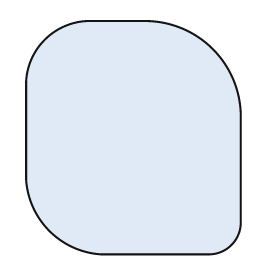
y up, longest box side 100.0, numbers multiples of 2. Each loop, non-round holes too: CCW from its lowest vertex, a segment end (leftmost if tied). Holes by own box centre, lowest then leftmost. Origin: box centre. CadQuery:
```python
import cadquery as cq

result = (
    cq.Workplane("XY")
    .moveTo(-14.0, -50.0)
    .lineTo(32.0, -50.0)
    .threePointArc((42.0, -46.0), (46.0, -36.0))
    .lineTo(46.0, 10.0)
    .threePointArc((34.0, 38.0), (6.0, 50.0))
    .lineTo(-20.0, 50.0)
    .threePointArc((-38.0, 42.0), (-46.0, 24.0))
    .lineTo(-46.0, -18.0)
    .threePointArc((-36.0, -40.0), (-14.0, -50.0))
    .close()
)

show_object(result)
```